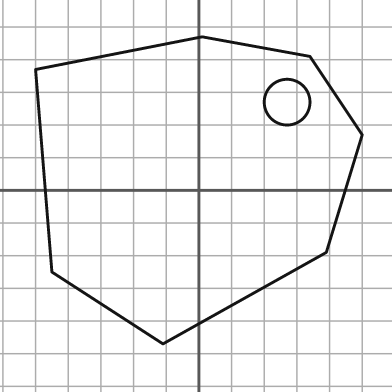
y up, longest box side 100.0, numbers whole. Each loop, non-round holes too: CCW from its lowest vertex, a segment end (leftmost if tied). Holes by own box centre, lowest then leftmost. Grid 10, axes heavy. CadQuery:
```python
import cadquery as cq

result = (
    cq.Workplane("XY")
    .moveTo(-11.0, -47.0)
    .lineTo(39.0, -19.0)
    .lineTo(50.0, 17.0)
    .lineTo(34.0, 41.0)
    .lineTo(1.0, 47.0)
    .lineTo(-50.0, 37.0)
    .lineTo(-45.0, -25.0)
    .close()
    .moveTo(27.0, 27.0)
    .circle(7.0)
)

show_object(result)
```